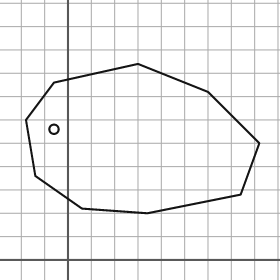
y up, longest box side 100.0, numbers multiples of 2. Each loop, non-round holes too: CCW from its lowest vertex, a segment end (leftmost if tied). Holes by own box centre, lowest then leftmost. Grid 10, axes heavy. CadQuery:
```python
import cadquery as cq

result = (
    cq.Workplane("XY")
    .moveTo(34.0, 20.0)
    .lineTo(74.0, 28.0)
    .lineTo(82.0, 50.0)
    .lineTo(60.0, 72.0)
    .lineTo(30.0, 84.0)
    .lineTo(-6.0, 76.0)
    .lineTo(-18.0, 60.0)
    .lineTo(-14.0, 36.0)
    .lineTo(6.0, 22.0)
    .close()
    .moveTo(-6.0, 56.0)
    .circle(2.0)
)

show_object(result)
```